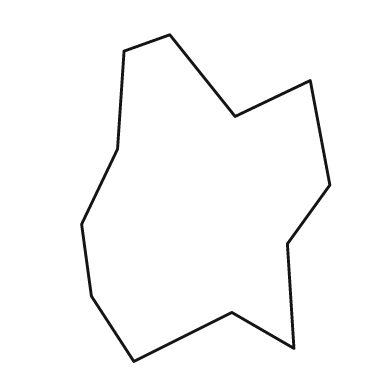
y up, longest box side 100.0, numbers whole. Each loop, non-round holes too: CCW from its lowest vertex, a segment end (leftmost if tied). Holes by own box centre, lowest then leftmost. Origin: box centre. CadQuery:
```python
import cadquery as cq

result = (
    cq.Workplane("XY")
    .moveTo(-22.0, -50.0)
    .lineTo(8.0, -35.0)
    .lineTo(27.0, -46.0)
    .lineTo(25.0, -14.0)
    .lineTo(38.0, 4.0)
    .lineTo(32.0, 36.0)
    .lineTo(9.0, 25.0)
    .lineTo(-11.0, 50.0)
    .lineTo(-25.0, 45.0)
    .lineTo(-27.0, 15.0)
    .lineTo(-38.0, -8.0)
    .lineTo(-35.0, -30.0)
    .close()
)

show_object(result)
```